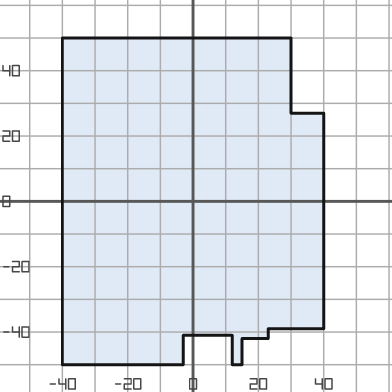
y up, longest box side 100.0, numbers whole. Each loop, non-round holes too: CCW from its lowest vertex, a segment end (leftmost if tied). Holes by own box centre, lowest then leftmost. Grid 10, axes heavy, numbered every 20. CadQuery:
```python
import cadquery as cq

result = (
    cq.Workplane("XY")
    .moveTo(-40.0, -50.0)
    .lineTo(-3.0, -50.0)
    .lineTo(-3.0, -41.0)
    .lineTo(12.0, -41.0)
    .lineTo(12.0, -50.0)
    .lineTo(15.0, -50.0)
    .lineTo(15.0, -42.0)
    .lineTo(23.0, -42.0)
    .lineTo(23.0, -39.0)
    .lineTo(40.0, -39.0)
    .lineTo(40.0, 27.0)
    .lineTo(30.0, 27.0)
    .lineTo(30.0, 50.0)
    .lineTo(-40.0, 50.0)
    .close()
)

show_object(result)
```